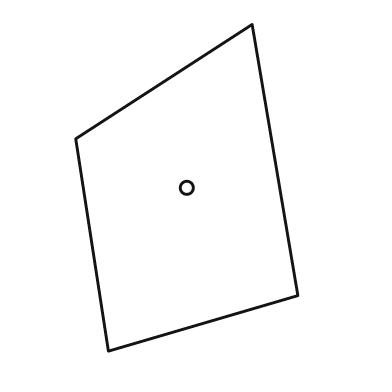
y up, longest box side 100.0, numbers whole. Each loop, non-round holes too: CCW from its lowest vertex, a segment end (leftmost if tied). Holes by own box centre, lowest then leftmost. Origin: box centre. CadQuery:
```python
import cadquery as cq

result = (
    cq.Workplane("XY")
    .moveTo(-24.0, -50.0)
    .lineTo(34.0, -33.0)
    .lineTo(20.0, 50.0)
    .lineTo(-34.0, 15.0)
    .close()
    .moveTo(0.0, 0.0)
    .circle(2.0)
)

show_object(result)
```